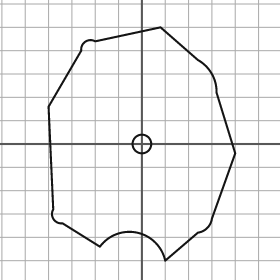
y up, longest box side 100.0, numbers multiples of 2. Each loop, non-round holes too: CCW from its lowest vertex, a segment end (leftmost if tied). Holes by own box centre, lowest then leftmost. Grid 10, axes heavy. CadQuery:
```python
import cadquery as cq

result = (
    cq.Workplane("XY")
    .moveTo(10.0, -50.0)
    .lineTo(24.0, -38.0)
    .threePointArc((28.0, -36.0), (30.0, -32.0))
    .lineTo(40.0, -4.0)
    .lineTo(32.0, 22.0)
    .threePointArc((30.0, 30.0), (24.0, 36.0))
    .lineTo(8.0, 50.0)
    .lineTo(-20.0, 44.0)
    .threePointArc((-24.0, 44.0), (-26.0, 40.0))
    .lineTo(-40.0, 16.0)
    .lineTo(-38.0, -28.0)
    .threePointArc((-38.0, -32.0), (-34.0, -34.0))
    .lineTo(-18.0, -44.0)
    .threePointArc((-2.0, -38.0), (10.0, -50.0))
    .close()
    .moveTo(0.0, 0.0)
    .circle(4.0)
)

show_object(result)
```